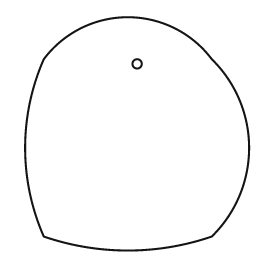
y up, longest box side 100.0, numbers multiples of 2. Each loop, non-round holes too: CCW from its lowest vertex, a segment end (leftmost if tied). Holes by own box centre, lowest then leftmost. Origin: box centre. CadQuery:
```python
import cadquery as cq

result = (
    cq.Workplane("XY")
    .moveTo(-40.0, -44.0)
    .threePointArc((-4.0, -50.0), (32.0, -44.0))
    .threePointArc((48.0, -6.0), (32.0, 32.0))
    .threePointArc((-4.0, 50.0), (-40.0, 32.0))
    .threePointArc((-48.0, -6.0), (-40.0, -44.0))
    .close()
    .moveTo(0.0, 30.0)
    .circle(2.0)
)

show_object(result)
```